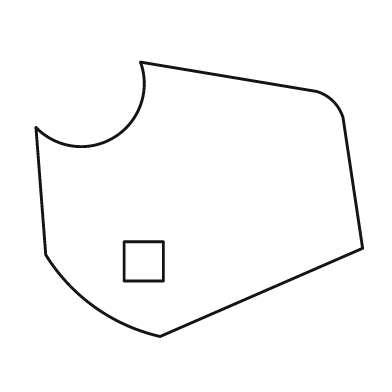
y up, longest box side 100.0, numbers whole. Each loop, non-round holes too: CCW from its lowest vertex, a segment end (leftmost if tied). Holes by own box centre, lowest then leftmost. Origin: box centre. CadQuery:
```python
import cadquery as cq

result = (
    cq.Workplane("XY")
    .moveTo(-12.0, -42.0)
    .lineTo(50.0, -15.0)
    .lineTo(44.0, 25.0)
    .threePointArc((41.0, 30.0), (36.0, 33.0))
    .lineTo(-18.0, 42.0)
    .threePointArc((-26.0, 19.0), (-50.0, 22.0))
    .lineTo(-47.0, -17.0)
    .threePointArc((-32.0, -33.0), (-12.0, -42.0))
    .close()
    .moveTo(-23.0, -25.0)
    .lineTo(-11.0, -25.0)
    .lineTo(-11.0, -13.0)
    .lineTo(-23.0, -13.0)
    .close()
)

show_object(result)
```